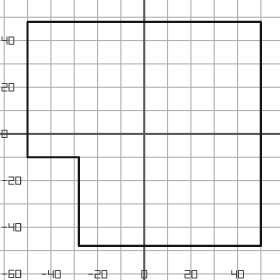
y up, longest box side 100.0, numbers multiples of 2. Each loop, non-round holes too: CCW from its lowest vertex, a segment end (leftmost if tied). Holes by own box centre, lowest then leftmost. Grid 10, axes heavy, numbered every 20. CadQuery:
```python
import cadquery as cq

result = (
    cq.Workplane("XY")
    .moveTo(-28.0, -48.0)
    .lineTo(50.0, -48.0)
    .lineTo(50.0, 48.0)
    .lineTo(-50.0, 48.0)
    .lineTo(-50.0, -10.0)
    .lineTo(-28.0, -10.0)
    .close()
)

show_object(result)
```